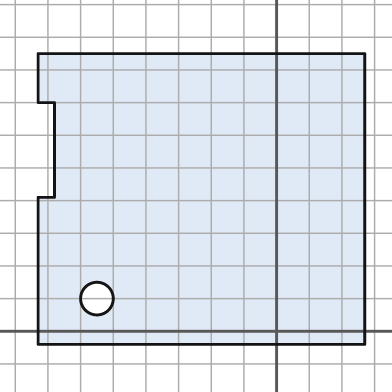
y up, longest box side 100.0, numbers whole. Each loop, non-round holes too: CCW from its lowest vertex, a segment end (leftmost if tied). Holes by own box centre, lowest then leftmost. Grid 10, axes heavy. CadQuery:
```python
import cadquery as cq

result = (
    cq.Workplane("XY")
    .moveTo(-73.0, -4.0)
    .lineTo(27.0, -4.0)
    .lineTo(27.0, 85.0)
    .lineTo(-73.0, 85.0)
    .lineTo(-73.0, 70.0)
    .lineTo(-68.0, 70.0)
    .lineTo(-68.0, 41.0)
    .lineTo(-73.0, 41.0)
    .close()
    .moveTo(-55.0, 10.0)
    .circle(5.0)
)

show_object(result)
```